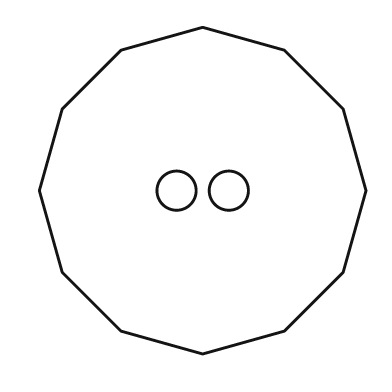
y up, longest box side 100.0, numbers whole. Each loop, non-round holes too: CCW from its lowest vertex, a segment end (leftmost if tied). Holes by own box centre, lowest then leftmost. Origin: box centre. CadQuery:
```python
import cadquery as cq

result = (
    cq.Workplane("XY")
    .moveTo(0.0, -50.0)
    .lineTo(25.0, -43.0)
    .lineTo(43.0, -25.0)
    .lineTo(50.0, 0.0)
    .lineTo(43.0, 25.0)
    .lineTo(25.0, 43.0)
    .lineTo(0.0, 50.0)
    .lineTo(-25.0, 43.0)
    .lineTo(-43.0, 25.0)
    .lineTo(-50.0, 0.0)
    .lineTo(-43.0, -25.0)
    .lineTo(-25.0, -43.0)
    .close()
    .moveTo(-8.0, 0.0)
    .circle(6.0)
    .moveTo(8.0, 0.0)
    .circle(6.0)
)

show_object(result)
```